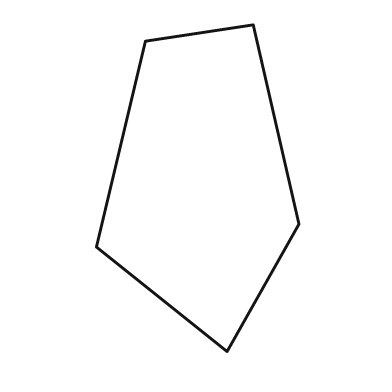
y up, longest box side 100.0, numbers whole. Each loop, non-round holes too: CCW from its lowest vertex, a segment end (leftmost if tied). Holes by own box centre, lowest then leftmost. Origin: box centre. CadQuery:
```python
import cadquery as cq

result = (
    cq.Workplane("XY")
    .moveTo(9.0, -50.0)
    .lineTo(31.0, -11.0)
    .lineTo(17.0, 50.0)
    .lineTo(-16.0, 45.0)
    .lineTo(-31.0, -18.0)
    .close()
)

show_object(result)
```